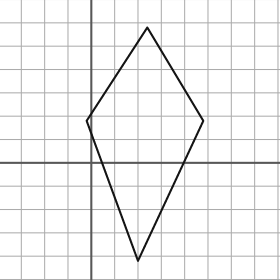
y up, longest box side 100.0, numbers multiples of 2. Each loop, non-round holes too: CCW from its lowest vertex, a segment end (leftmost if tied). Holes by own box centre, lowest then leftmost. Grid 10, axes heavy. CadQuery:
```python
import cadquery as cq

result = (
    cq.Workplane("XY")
    .moveTo(20.0, -42.0)
    .lineTo(48.0, 18.0)
    .lineTo(24.0, 58.0)
    .lineTo(-2.0, 18.0)
    .close()
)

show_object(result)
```